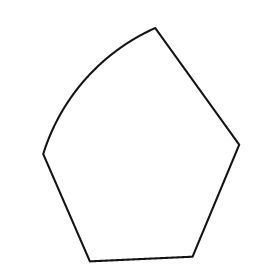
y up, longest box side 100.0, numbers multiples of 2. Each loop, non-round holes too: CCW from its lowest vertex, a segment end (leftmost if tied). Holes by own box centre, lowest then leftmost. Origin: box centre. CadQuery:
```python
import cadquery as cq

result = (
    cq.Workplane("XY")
    .moveTo(-22.0, -50.0)
    .lineTo(22.0, -48.0)
    .lineTo(42.0, 0.0)
    .lineTo(6.0, 50.0)
    .threePointArc((-24.0, 28.0), (-42.0, -4.0))
    .close()
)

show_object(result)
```